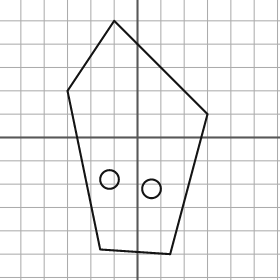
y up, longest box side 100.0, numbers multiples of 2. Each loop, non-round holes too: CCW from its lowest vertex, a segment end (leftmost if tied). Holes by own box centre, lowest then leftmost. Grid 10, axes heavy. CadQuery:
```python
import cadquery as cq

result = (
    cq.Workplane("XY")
    .moveTo(14.0, -50.0)
    .lineTo(30.0, 10.0)
    .lineTo(-10.0, 50.0)
    .lineTo(-30.0, 20.0)
    .lineTo(-16.0, -48.0)
    .close()
    .moveTo(6.0, -22.0)
    .circle(4.0)
    .moveTo(-12.0, -18.0)
    .circle(4.0)
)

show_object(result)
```